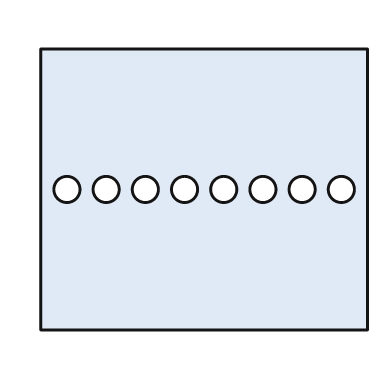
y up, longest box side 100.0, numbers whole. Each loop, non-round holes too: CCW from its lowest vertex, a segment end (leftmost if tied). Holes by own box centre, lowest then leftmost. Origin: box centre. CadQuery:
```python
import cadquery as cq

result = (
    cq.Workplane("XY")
    .moveTo(-50.0, -43.0)
    .lineTo(50.0, -43.0)
    .lineTo(50.0, 43.0)
    .lineTo(-50.0, 43.0)
    .close()
    .moveTo(-42.0, 0.0)
    .circle(4.0)
    .moveTo(-30.0, 0.0)
    .circle(4.0)
    .moveTo(-18.0, 0.0)
    .circle(4.0)
    .moveTo(-6.0, 0.0)
    .circle(4.0)
    .moveTo(6.0, 0.0)
    .circle(4.0)
    .moveTo(18.0, 0.0)
    .circle(4.0)
    .moveTo(30.0, 0.0)
    .circle(4.0)
    .moveTo(42.0, 0.0)
    .circle(4.0)
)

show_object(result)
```